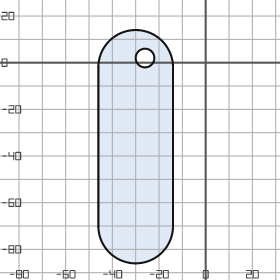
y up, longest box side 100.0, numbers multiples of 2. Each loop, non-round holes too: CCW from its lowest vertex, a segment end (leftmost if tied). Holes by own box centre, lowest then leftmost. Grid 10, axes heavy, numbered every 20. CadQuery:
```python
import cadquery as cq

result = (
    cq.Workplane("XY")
    .moveTo(-46.0, -70.0)
    .threePointArc((-30.0, -86.0), (-14.0, -70.0))
    .lineTo(-14.0, -2.0)
    .threePointArc((-30.0, 14.0), (-46.0, -2.0))
    .close()
    .moveTo(-26.0, 2.0)
    .circle(4.0)
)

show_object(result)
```